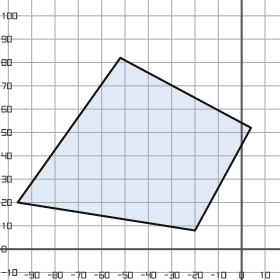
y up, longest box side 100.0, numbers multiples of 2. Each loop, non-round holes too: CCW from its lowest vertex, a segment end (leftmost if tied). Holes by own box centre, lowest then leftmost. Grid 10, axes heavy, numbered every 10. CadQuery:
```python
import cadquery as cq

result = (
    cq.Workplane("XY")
    .moveTo(-20.0, 8.0)
    .lineTo(4.0, 52.0)
    .lineTo(-52.0, 82.0)
    .lineTo(-96.0, 20.0)
    .close()
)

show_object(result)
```